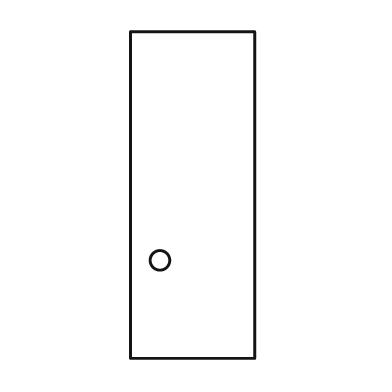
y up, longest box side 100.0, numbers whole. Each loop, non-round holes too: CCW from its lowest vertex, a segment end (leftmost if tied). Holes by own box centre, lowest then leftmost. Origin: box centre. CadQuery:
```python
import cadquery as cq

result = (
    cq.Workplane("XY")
    .moveTo(-19.0, -50.0)
    .lineTo(19.0, -50.0)
    .lineTo(19.0, 50.0)
    .lineTo(-19.0, 50.0)
    .close()
    .moveTo(-10.0, -20.0)
    .circle(3.0)
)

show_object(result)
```